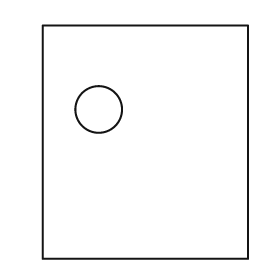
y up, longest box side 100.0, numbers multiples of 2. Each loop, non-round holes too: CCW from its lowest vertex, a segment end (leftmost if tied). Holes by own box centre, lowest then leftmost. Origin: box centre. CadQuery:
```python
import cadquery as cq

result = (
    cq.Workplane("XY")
    .moveTo(-44.0, -50.0)
    .lineTo(44.0, -50.0)
    .lineTo(44.0, 50.0)
    .lineTo(-44.0, 50.0)
    .close()
    .moveTo(-20.0, 14.0)
    .circle(10.0)
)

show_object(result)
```